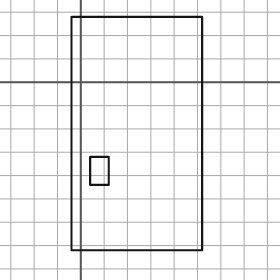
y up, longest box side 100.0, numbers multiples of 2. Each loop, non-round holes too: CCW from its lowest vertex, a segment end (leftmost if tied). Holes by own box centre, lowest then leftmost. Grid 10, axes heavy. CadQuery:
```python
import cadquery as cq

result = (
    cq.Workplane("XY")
    .moveTo(-4.0, -72.0)
    .lineTo(52.0, -72.0)
    .lineTo(52.0, 28.0)
    .lineTo(-4.0, 28.0)
    .close()
    .moveTo(4.0, -44.0)
    .lineTo(12.0, -44.0)
    .lineTo(12.0, -32.0)
    .lineTo(4.0, -32.0)
    .close()
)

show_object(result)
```